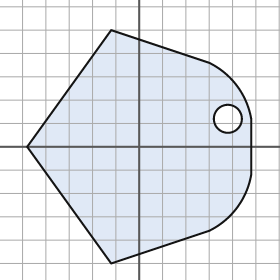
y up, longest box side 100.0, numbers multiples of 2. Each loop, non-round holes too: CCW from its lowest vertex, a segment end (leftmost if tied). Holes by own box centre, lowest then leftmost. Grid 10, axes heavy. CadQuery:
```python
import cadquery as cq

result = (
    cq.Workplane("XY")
    .moveTo(-12.0, -50.0)
    .lineTo(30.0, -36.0)
    .threePointArc((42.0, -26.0), (48.0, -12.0))
    .lineTo(48.0, 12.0)
    .threePointArc((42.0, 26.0), (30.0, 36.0))
    .lineTo(-12.0, 50.0)
    .lineTo(-48.0, 0.0)
    .close()
    .moveTo(38.0, 12.0)
    .circle(6.0)
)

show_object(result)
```